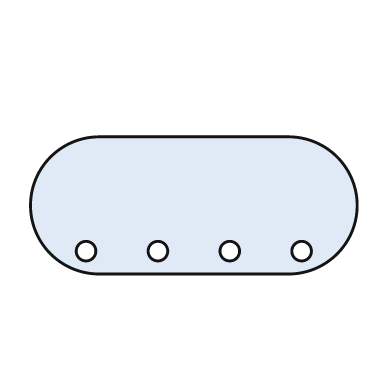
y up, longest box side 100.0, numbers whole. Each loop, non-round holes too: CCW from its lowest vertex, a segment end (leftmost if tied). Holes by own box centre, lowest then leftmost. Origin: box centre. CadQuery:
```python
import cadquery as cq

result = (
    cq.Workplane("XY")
    .moveTo(-29.0, -21.0)
    .lineTo(29.0, -21.0)
    .threePointArc((50.0, 0.0), (29.0, 21.0))
    .lineTo(-29.0, 21.0)
    .threePointArc((-50.0, 0.0), (-29.0, -21.0))
    .close()
    .moveTo(-33.0, -14.0)
    .circle(3.0)
    .moveTo(-11.0, -14.0)
    .circle(3.0)
    .moveTo(11.0, -14.0)
    .circle(3.0)
    .moveTo(33.0, -14.0)
    .circle(3.0)
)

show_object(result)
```